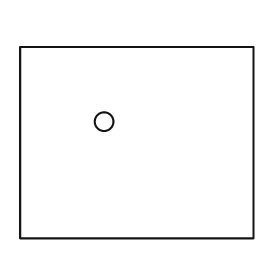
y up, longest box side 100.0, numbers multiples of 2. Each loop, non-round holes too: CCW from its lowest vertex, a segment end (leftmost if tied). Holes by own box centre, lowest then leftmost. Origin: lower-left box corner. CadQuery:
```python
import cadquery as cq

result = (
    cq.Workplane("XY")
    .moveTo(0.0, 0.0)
    .lineTo(100.0, 0.0)
    .lineTo(100.0, 82.0)
    .lineTo(0.0, 82.0)
    .close()
    .moveTo(36.0, 50.0)
    .circle(4.0)
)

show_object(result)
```